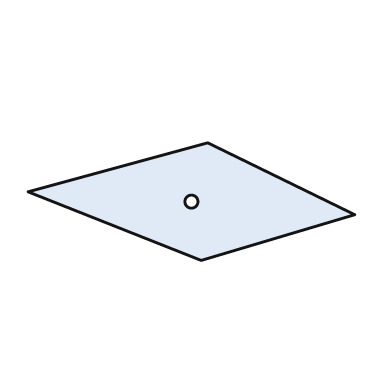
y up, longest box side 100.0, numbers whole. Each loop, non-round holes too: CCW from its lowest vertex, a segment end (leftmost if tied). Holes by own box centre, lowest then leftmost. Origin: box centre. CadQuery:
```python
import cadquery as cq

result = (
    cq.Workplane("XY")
    .moveTo(3.0, -18.0)
    .lineTo(50.0, -4.0)
    .lineTo(5.0, 18.0)
    .lineTo(-50.0, 3.0)
    .close()
    .moveTo(0.0, 0.0)
    .circle(2.0)
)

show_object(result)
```